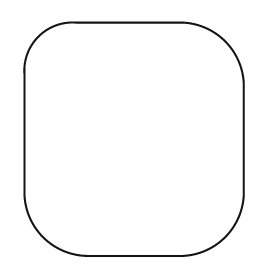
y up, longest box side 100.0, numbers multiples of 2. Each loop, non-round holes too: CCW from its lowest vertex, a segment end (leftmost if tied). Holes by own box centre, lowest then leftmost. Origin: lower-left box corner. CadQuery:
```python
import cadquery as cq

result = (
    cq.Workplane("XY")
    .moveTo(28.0, 0.0)
    .lineTo(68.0, 0.0)
    .threePointArc((86.0, 8.0), (94.0, 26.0))
    .lineTo(94.0, 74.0)
    .threePointArc((86.0, 92.0), (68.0, 100.0))
    .lineTo(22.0, 100.0)
    .threePointArc((6.0, 94.0), (0.0, 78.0))
    .lineTo(0.0, 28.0)
    .threePointArc((8.0, 8.0), (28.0, 0.0))
    .close()
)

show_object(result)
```